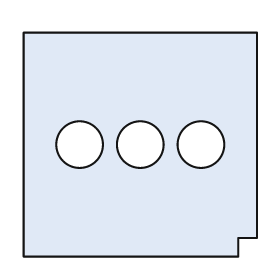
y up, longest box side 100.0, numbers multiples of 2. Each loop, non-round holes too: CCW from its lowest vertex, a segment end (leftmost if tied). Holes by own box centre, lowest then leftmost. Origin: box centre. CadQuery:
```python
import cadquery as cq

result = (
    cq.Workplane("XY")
    .moveTo(-50.0, -48.0)
    .lineTo(42.0, -48.0)
    .lineTo(42.0, -40.0)
    .lineTo(50.0, -40.0)
    .lineTo(50.0, 48.0)
    .lineTo(-50.0, 48.0)
    .close()
    .moveTo(-26.0, 0.0)
    .circle(10.0)
    .moveTo(0.0, 0.0)
    .circle(10.0)
    .moveTo(26.0, 0.0)
    .circle(10.0)
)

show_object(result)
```